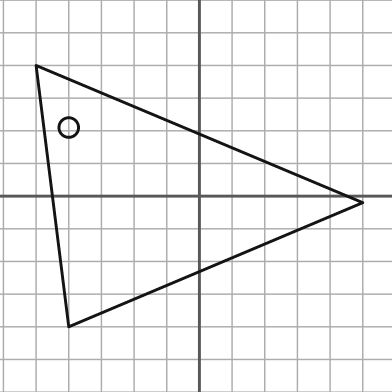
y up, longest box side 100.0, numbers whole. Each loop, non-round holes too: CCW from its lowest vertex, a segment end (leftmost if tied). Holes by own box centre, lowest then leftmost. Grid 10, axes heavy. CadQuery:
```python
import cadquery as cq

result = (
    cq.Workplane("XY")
    .moveTo(-40.0, -40.0)
    .lineTo(50.0, -2.0)
    .lineTo(-50.0, 40.0)
    .close()
    .moveTo(-40.0, 21.0)
    .circle(3.0)
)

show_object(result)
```